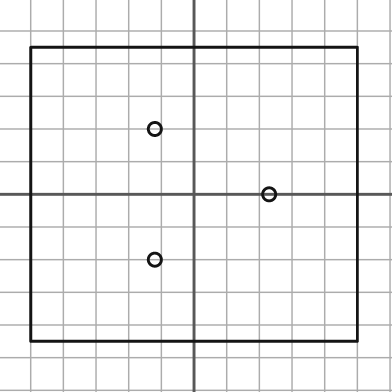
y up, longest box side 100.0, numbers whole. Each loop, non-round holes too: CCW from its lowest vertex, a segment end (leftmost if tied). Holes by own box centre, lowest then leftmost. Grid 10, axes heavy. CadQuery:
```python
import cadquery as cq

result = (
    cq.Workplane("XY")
    .moveTo(-50.0, -45.0)
    .lineTo(50.0, -45.0)
    .lineTo(50.0, 45.0)
    .lineTo(-50.0, 45.0)
    .close()
    .moveTo(-12.0, -20.0)
    .circle(2.0)
    .moveTo(23.0, 0.0)
    .circle(2.0)
    .moveTo(-12.0, 20.0)
    .circle(2.0)
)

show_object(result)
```